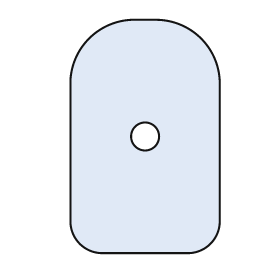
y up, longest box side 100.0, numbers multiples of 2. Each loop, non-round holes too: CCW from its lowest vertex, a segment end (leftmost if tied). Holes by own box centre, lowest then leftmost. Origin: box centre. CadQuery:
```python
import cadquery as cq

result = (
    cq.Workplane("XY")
    .moveTo(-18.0, -50.0)
    .lineTo(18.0, -50.0)
    .threePointArc((28.0, -46.0), (32.0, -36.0))
    .lineTo(32.0, 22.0)
    .threePointArc((24.0, 42.0), (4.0, 50.0))
    .lineTo(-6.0, 50.0)
    .threePointArc((-24.0, 42.0), (-32.0, 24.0))
    .lineTo(-32.0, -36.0)
    .threePointArc((-28.0, -46.0), (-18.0, -50.0))
    .close()
    .moveTo(0.0, 0.0)
    .circle(6.0)
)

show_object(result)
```